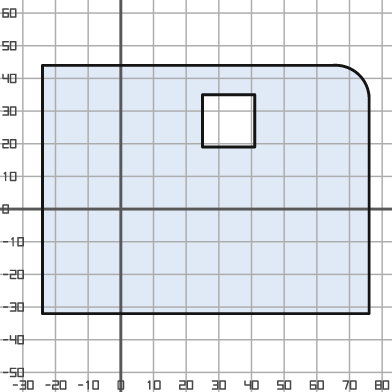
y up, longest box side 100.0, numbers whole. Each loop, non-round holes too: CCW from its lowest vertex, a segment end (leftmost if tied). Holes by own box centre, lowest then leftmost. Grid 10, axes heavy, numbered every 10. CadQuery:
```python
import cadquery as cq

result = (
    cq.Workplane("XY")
    .moveTo(-24.0, -32.0)
    .lineTo(76.0, -32.0)
    .lineTo(76.0, 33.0)
    .threePointArc((73.0, 41.0), (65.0, 44.0))
    .lineTo(-24.0, 44.0)
    .close()
    .moveTo(25.0, 19.0)
    .lineTo(41.0, 19.0)
    .lineTo(41.0, 35.0)
    .lineTo(25.0, 35.0)
    .close()
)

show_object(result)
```